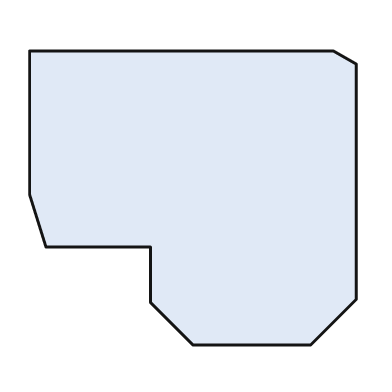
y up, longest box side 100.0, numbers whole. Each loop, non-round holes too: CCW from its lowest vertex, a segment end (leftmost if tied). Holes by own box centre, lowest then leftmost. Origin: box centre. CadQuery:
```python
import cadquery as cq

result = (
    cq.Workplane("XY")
    .moveTo(0.0, -45.0)
    .lineTo(36.0, -45.0)
    .lineTo(50.0, -31.0)
    .lineTo(50.0, 41.0)
    .lineTo(43.0, 45.0)
    .lineTo(-50.0, 45.0)
    .lineTo(-50.0, 1.0)
    .lineTo(-45.0, -15.0)
    .lineTo(-13.0, -15.0)
    .lineTo(-13.0, -32.0)
    .close()
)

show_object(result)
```